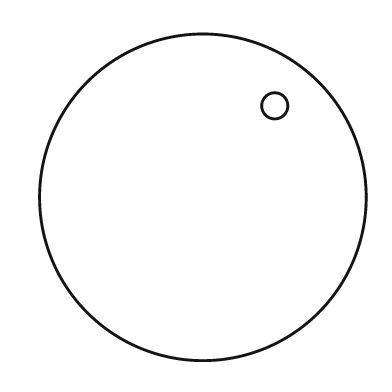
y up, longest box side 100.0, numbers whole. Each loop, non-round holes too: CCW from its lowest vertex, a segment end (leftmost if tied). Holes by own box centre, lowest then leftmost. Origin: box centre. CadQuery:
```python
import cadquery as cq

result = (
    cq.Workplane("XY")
    .moveTo(0.0, 0.0)
    .circle(50.0)
    .moveTo(22.0, 28.0)
    .circle(4.0)
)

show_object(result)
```